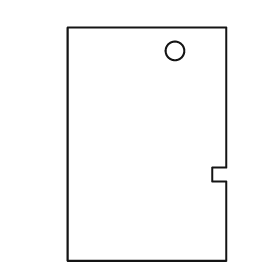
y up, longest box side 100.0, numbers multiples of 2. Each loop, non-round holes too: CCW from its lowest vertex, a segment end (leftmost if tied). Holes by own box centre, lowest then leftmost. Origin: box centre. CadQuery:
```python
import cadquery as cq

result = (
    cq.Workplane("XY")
    .moveTo(-34.0, -50.0)
    .lineTo(34.0, -50.0)
    .lineTo(34.0, -16.0)
    .lineTo(28.0, -16.0)
    .lineTo(28.0, -10.0)
    .lineTo(34.0, -10.0)
    .lineTo(34.0, 50.0)
    .lineTo(-34.0, 50.0)
    .close()
    .moveTo(12.0, 40.0)
    .circle(4.0)
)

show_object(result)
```